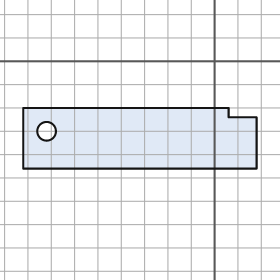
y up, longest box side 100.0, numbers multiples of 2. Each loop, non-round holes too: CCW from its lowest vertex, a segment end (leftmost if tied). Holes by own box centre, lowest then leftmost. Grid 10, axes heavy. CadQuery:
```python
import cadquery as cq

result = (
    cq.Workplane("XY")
    .moveTo(-82.0, -46.0)
    .lineTo(18.0, -46.0)
    .lineTo(18.0, -24.0)
    .lineTo(6.0, -24.0)
    .lineTo(6.0, -20.0)
    .lineTo(-82.0, -20.0)
    .close()
    .moveTo(-72.0, -30.0)
    .circle(4.0)
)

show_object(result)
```